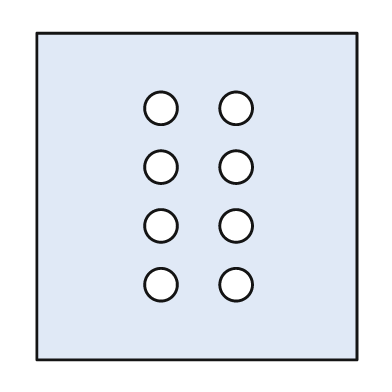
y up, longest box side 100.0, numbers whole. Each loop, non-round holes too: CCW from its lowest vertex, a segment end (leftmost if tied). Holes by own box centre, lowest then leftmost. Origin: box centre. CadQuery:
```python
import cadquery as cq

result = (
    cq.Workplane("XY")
    .moveTo(-49.0, -50.0)
    .lineTo(49.0, -50.0)
    .lineTo(49.0, 50.0)
    .lineTo(-49.0, 50.0)
    .close()
    .moveTo(-11.0, -27.0)
    .circle(5.0)
    .moveTo(12.0, -27.0)
    .circle(5.0)
    .moveTo(-11.0, -9.0)
    .circle(5.0)
    .moveTo(12.0, -9.0)
    .circle(5.0)
    .moveTo(-11.0, 9.0)
    .circle(5.0)
    .moveTo(12.0, 9.0)
    .circle(5.0)
    .moveTo(-11.0, 27.0)
    .circle(5.0)
    .moveTo(12.0, 27.0)
    .circle(5.0)
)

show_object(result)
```